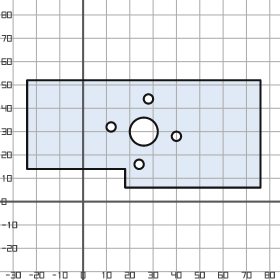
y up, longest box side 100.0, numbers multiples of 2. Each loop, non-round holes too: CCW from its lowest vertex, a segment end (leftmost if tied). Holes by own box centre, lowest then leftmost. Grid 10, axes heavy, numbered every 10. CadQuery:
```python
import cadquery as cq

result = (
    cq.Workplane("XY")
    .moveTo(18.0, 6.0)
    .lineTo(76.0, 6.0)
    .lineTo(76.0, 52.0)
    .lineTo(-24.0, 52.0)
    .lineTo(-24.0, 14.0)
    .lineTo(18.0, 14.0)
    .close()
    .moveTo(24.0, 16.0)
    .circle(2.0)
    .moveTo(40.0, 28.0)
    .circle(2.0)
    .moveTo(26.0, 30.0)
    .circle(6.0)
    .moveTo(12.0, 32.0)
    .circle(2.0)
    .moveTo(28.0, 44.0)
    .circle(2.0)
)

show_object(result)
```